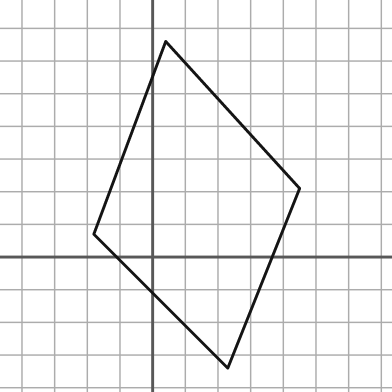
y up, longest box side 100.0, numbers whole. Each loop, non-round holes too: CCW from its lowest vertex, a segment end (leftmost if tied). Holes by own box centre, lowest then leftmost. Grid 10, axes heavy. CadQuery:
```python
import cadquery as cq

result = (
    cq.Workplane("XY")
    .moveTo(23.0, -34.0)
    .lineTo(45.0, 21.0)
    .lineTo(4.0, 66.0)
    .lineTo(-18.0, 7.0)
    .close()
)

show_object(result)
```